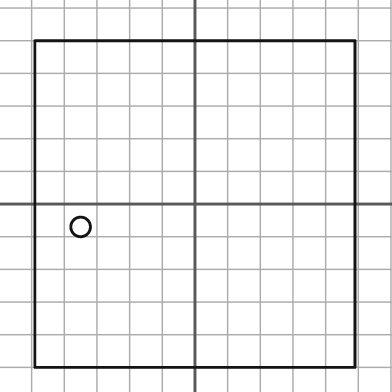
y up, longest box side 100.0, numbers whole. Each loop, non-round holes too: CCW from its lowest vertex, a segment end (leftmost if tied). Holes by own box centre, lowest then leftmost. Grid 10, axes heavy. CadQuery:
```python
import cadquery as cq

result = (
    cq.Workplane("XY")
    .moveTo(-49.0, -50.0)
    .lineTo(49.0, -50.0)
    .lineTo(49.0, 50.0)
    .lineTo(-49.0, 50.0)
    .close()
    .moveTo(-35.0, -7.0)
    .circle(3.0)
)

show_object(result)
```